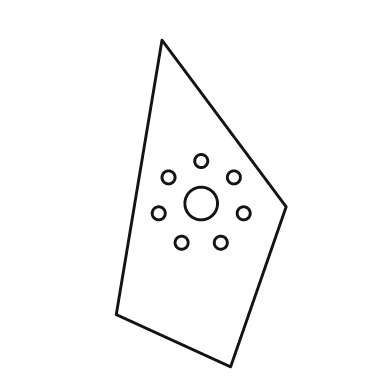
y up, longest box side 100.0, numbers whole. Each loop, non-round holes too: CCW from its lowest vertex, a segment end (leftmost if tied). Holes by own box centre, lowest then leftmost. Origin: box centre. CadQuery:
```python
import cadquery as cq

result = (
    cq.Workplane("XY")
    .moveTo(9.0, -50.0)
    .lineTo(26.0, -1.0)
    .lineTo(-12.0, 50.0)
    .lineTo(-26.0, -34.0)
    .close()
    .moveTo(-6.0, -12.0)
    .circle(2.0)
    .moveTo(6.0, -12.0)
    .circle(2.0)
    .moveTo(-13.0, -3.0)
    .circle(2.0)
    .moveTo(13.0, -3.0)
    .circle(2.0)
    .moveTo(0.0, 0.0)
    .circle(5.0)
    .moveTo(-10.0, 8.0)
    .circle(2.0)
    .moveTo(10.0, 8.0)
    .circle(2.0)
    .moveTo(0.0, 13.0)
    .circle(2.0)
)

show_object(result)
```